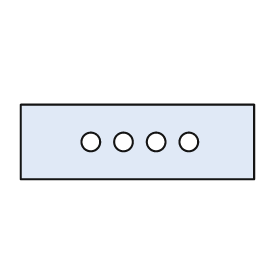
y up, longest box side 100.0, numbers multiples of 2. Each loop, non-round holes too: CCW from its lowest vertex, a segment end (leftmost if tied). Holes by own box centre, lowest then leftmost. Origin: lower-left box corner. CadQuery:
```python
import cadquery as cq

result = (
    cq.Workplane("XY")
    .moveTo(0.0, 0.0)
    .lineTo(100.0, 0.0)
    .lineTo(100.0, 32.0)
    .lineTo(0.0, 32.0)
    .close()
    .moveTo(30.0, 16.0)
    .circle(4.0)
    .moveTo(44.0, 16.0)
    .circle(4.0)
    .moveTo(58.0, 16.0)
    .circle(4.0)
    .moveTo(72.0, 16.0)
    .circle(4.0)
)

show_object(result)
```